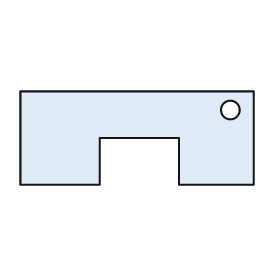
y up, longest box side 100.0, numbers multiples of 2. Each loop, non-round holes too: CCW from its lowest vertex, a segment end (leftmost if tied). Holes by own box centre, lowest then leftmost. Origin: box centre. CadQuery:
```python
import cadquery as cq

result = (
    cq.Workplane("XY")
    .moveTo(-50.0, -20.0)
    .lineTo(-16.0, -20.0)
    .lineTo(-16.0, 0.0)
    .lineTo(18.0, 0.0)
    .lineTo(18.0, -20.0)
    .lineTo(50.0, -20.0)
    .lineTo(50.0, 20.0)
    .lineTo(-50.0, 20.0)
    .close()
    .moveTo(40.0, 12.0)
    .circle(4.0)
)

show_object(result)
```